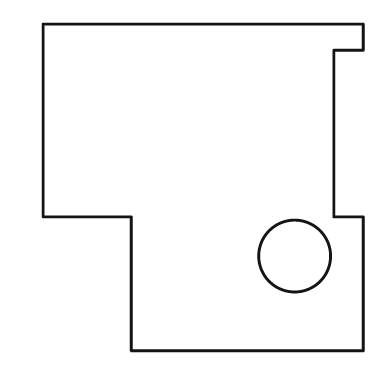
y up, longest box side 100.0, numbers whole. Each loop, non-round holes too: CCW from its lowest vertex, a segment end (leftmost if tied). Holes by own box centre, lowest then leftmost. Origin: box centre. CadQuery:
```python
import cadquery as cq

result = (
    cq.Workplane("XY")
    .moveTo(-22.0, -50.0)
    .lineTo(49.0, -50.0)
    .lineTo(49.0, -9.0)
    .lineTo(40.0, -9.0)
    .lineTo(40.0, 42.0)
    .lineTo(49.0, 42.0)
    .lineTo(49.0, 50.0)
    .lineTo(-49.0, 50.0)
    .lineTo(-49.0, -9.0)
    .lineTo(-22.0, -9.0)
    .close()
    .moveTo(28.0, -21.0)
    .circle(11.0)
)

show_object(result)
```